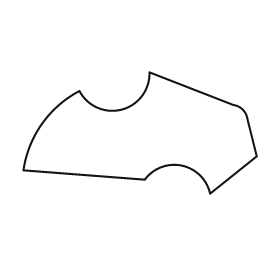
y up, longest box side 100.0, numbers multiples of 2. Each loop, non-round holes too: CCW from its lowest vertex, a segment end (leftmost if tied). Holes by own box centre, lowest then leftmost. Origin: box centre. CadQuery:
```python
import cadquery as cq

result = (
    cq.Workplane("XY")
    .moveTo(30.0, -26.0)
    .lineTo(50.0, -10.0)
    .lineTo(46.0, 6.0)
    .threePointArc((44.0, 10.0), (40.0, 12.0))
    .lineTo(4.0, 26.0)
    .threePointArc((-8.0, 10.0), (-26.0, 18.0))
    .threePointArc((-42.0, 4.0), (-50.0, -16.0))
    .lineTo(2.0, -20.0)
    .threePointArc((18.0, -14.0), (30.0, -26.0))
    .close()
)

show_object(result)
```